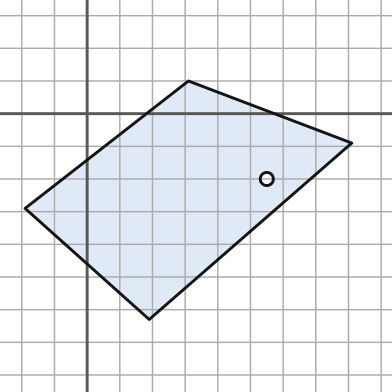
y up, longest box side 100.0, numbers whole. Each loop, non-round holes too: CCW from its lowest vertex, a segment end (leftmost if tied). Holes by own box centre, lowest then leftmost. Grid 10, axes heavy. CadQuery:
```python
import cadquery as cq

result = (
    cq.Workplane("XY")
    .moveTo(19.0, -63.0)
    .lineTo(81.0, -9.0)
    .lineTo(31.0, 10.0)
    .lineTo(-19.0, -29.0)
    .close()
    .moveTo(55.0, -20.0)
    .circle(2.0)
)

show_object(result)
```